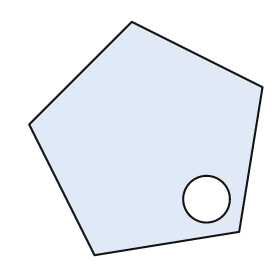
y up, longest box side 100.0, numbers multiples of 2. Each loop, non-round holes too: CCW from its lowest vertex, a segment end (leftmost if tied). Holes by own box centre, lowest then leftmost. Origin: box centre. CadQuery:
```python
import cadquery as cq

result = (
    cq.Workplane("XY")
    .moveTo(-22.0, -50.0)
    .lineTo(40.0, -40.0)
    .lineTo(50.0, 22.0)
    .lineTo(-6.0, 50.0)
    .lineTo(-50.0, 6.0)
    .close()
    .moveTo(26.0, -26.0)
    .circle(10.0)
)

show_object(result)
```